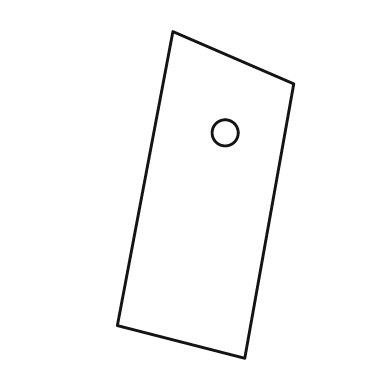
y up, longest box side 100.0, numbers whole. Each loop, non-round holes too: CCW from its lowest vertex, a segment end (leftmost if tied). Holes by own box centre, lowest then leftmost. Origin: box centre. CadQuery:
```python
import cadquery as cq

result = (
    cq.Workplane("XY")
    .moveTo(12.0, -50.0)
    .lineTo(27.0, 34.0)
    .lineTo(-10.0, 50.0)
    .lineTo(-27.0, -40.0)
    .close()
    .moveTo(6.0, 19.0)
    .circle(4.0)
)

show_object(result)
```